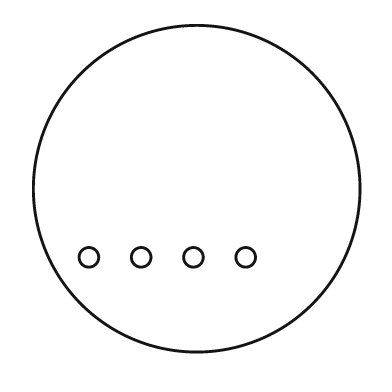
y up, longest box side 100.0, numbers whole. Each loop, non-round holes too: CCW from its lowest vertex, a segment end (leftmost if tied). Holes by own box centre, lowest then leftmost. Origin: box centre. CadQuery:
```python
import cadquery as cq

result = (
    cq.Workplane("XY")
    .moveTo(0.0, 0.0)
    .circle(50.0)
    .moveTo(-33.0, -21.0)
    .circle(3.0)
    .moveTo(-17.0, -21.0)
    .circle(3.0)
    .moveTo(-1.0, -21.0)
    .circle(3.0)
    .moveTo(15.0, -21.0)
    .circle(3.0)
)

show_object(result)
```